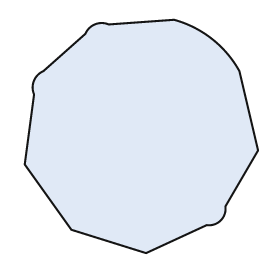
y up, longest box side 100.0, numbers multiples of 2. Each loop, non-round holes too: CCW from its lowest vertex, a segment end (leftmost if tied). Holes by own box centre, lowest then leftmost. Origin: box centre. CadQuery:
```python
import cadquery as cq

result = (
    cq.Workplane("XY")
    .moveTo(2.0, -50.0)
    .lineTo(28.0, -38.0)
    .threePointArc((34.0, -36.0), (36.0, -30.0))
    .lineTo(50.0, -6.0)
    .lineTo(42.0, 28.0)
    .threePointArc((30.0, 42.0), (14.0, 50.0))
    .lineTo(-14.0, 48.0)
    .threePointArc((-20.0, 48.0), (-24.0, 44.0))
    .lineTo(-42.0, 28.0)
    .threePointArc((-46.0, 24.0), (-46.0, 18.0))
    .lineTo(-50.0, -12.0)
    .lineTo(-30.0, -40.0)
    .close()
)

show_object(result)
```